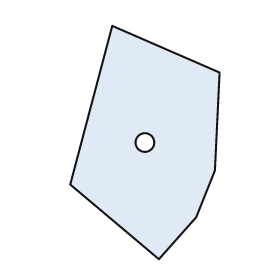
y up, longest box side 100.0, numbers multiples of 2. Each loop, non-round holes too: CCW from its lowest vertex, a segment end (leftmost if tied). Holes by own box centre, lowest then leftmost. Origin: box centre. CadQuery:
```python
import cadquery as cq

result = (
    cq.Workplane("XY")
    .moveTo(6.0, -50.0)
    .lineTo(22.0, -32.0)
    .lineTo(30.0, -12.0)
    .lineTo(32.0, 30.0)
    .lineTo(-14.0, 50.0)
    .lineTo(-32.0, -18.0)
    .close()
    .moveTo(0.0, 0.0)
    .circle(4.0)
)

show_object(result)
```